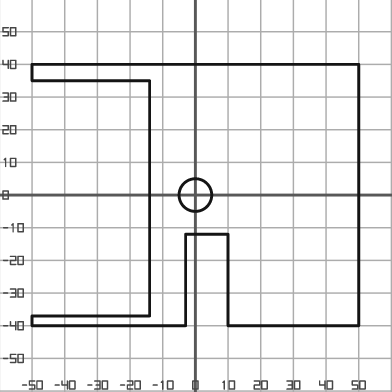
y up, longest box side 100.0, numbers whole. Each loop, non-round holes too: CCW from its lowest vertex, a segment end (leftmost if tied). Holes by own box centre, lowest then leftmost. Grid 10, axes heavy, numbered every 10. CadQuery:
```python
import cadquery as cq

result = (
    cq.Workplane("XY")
    .moveTo(-50.0, -40.0)
    .lineTo(-3.0, -40.0)
    .lineTo(-3.0, -12.0)
    .lineTo(10.0, -12.0)
    .lineTo(10.0, -40.0)
    .lineTo(50.0, -40.0)
    .lineTo(50.0, 40.0)
    .lineTo(-50.0, 40.0)
    .lineTo(-50.0, 35.0)
    .lineTo(-14.0, 35.0)
    .lineTo(-14.0, -37.0)
    .lineTo(-50.0, -37.0)
    .close()
    .moveTo(0.0, 0.0)
    .circle(5.0)
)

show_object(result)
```